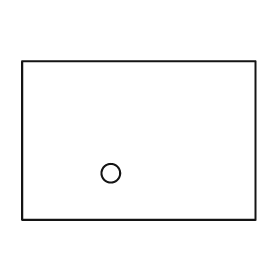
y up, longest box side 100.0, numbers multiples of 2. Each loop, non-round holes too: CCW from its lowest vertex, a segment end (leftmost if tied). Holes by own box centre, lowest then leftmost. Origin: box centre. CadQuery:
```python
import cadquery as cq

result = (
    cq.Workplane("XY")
    .moveTo(-50.0, -34.0)
    .lineTo(50.0, -34.0)
    .lineTo(50.0, 34.0)
    .lineTo(-50.0, 34.0)
    .close()
    .moveTo(-12.0, -14.0)
    .circle(4.0)
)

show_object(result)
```